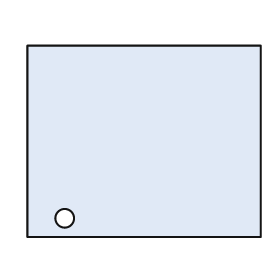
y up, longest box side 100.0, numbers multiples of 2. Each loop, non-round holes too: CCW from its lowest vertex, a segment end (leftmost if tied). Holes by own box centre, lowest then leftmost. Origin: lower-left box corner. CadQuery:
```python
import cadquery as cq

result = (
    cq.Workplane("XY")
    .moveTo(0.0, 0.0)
    .lineTo(100.0, 0.0)
    .lineTo(100.0, 82.0)
    .lineTo(0.0, 82.0)
    .close()
    .moveTo(16.0, 8.0)
    .circle(4.0)
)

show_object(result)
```